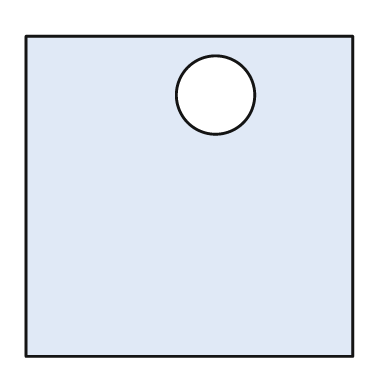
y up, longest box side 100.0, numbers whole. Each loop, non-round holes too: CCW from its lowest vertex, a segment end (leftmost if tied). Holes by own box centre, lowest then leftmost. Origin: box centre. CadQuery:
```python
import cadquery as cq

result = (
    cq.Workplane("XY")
    .moveTo(-50.0, -49.0)
    .lineTo(50.0, -49.0)
    .lineTo(50.0, 49.0)
    .lineTo(-50.0, 49.0)
    .close()
    .moveTo(8.0, 31.0)
    .circle(12.0)
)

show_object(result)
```